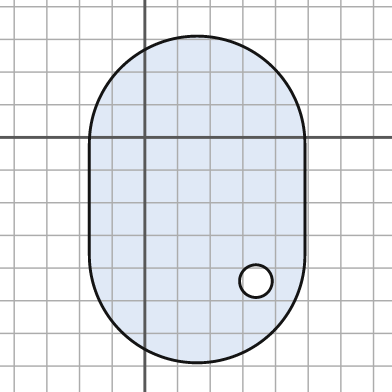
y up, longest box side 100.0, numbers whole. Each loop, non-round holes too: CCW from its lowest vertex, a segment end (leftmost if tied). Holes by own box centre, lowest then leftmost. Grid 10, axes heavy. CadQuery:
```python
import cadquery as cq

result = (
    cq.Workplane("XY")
    .moveTo(-17.0, -36.0)
    .threePointArc((16.0, -69.0), (49.0, -36.0))
    .lineTo(49.0, -2.0)
    .threePointArc((16.0, 31.0), (-17.0, -2.0))
    .close()
    .moveTo(34.0, -44.0)
    .circle(5.0)
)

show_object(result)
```